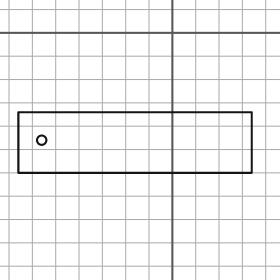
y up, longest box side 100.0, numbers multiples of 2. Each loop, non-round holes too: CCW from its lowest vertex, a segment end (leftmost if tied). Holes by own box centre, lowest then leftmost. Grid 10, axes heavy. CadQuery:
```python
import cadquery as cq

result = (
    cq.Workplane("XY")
    .moveTo(-66.0, -60.0)
    .lineTo(34.0, -60.0)
    .lineTo(34.0, -34.0)
    .lineTo(-66.0, -34.0)
    .close()
    .moveTo(-56.0, -46.0)
    .circle(2.0)
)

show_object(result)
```